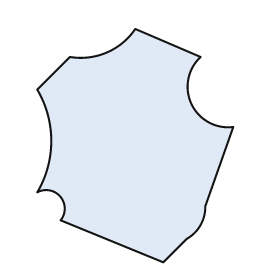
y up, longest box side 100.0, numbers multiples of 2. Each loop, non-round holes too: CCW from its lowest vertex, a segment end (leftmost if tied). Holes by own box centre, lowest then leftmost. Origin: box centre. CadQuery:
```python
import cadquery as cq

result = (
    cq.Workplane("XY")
    .moveTo(12.0, -50.0)
    .lineTo(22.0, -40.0)
    .threePointArc((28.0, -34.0), (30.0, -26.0))
    .lineTo(42.0, 8.0)
    .threePointArc((24.0, 18.0), (28.0, 38.0))
    .lineTo(0.0, 50.0)
    .threePointArc((-12.0, 40.0), (-28.0, 38.0))
    .lineTo(-42.0, 24.0)
    .threePointArc((-36.0, 2.0), (-42.0, -20.0))
    .threePointArc((-32.0, -22.0), (-32.0, -32.0))
    .close()
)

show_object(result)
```